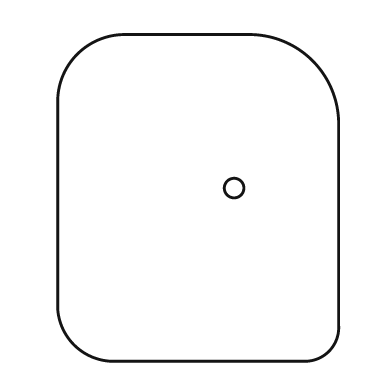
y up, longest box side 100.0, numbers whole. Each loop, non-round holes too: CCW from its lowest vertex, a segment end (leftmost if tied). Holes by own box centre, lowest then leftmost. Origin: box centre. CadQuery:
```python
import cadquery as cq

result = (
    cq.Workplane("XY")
    .moveTo(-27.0, -50.0)
    .lineTo(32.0, -50.0)
    .threePointArc((40.0, -47.0), (43.0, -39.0))
    .lineTo(43.0, 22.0)
    .threePointArc((35.0, 42.0), (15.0, 50.0))
    .lineTo(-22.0, 50.0)
    .threePointArc((-37.0, 44.0), (-43.0, 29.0))
    .lineTo(-43.0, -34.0)
    .threePointArc((-38.0, -45.0), (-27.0, -50.0))
    .close()
    .moveTo(11.0, 3.0)
    .circle(3.0)
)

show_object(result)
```